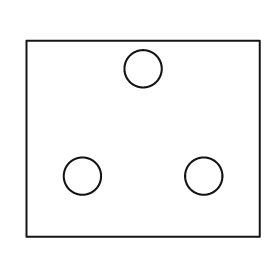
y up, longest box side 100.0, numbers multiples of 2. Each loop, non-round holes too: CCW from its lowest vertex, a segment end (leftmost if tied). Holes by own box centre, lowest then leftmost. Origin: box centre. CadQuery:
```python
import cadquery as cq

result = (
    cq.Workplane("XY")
    .moveTo(-50.0, -42.0)
    .lineTo(50.0, -42.0)
    .lineTo(50.0, 42.0)
    .lineTo(-50.0, 42.0)
    .close()
    .moveTo(-26.0, -16.0)
    .circle(8.0)
    .moveTo(26.0, -16.0)
    .circle(8.0)
    .moveTo(0.0, 30.0)
    .circle(8.0)
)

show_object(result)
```